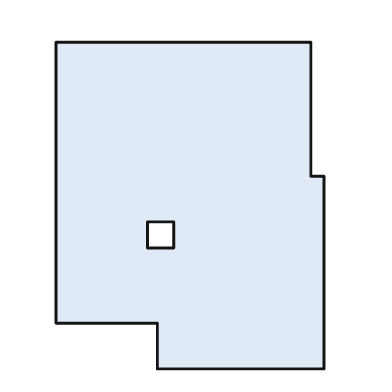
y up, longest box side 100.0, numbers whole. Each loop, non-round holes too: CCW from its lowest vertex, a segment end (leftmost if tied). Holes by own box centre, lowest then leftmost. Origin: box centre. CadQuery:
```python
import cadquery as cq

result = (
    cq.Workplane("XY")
    .moveTo(-10.0, -50.0)
    .lineTo(41.0, -50.0)
    .lineTo(41.0, 9.0)
    .lineTo(37.0, 9.0)
    .lineTo(37.0, 50.0)
    .lineTo(-41.0, 50.0)
    .lineTo(-41.0, -36.0)
    .lineTo(-10.0, -36.0)
    .close()
    .moveTo(-13.0, -13.0)
    .lineTo(-5.0, -13.0)
    .lineTo(-5.0, -5.0)
    .lineTo(-13.0, -5.0)
    .close()
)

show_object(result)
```